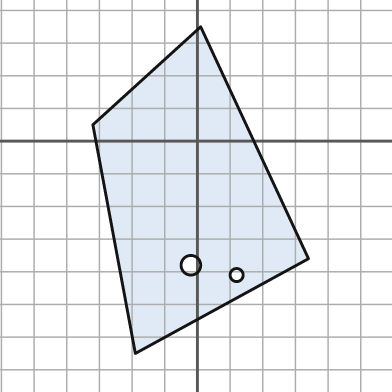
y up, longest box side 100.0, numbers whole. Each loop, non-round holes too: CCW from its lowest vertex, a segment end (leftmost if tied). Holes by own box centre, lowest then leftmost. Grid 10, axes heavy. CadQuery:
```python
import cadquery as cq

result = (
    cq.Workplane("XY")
    .moveTo(-19.0, -65.0)
    .lineTo(34.0, -36.0)
    .lineTo(1.0, 35.0)
    .lineTo(-32.0, 5.0)
    .close()
    .moveTo(12.0, -41.0)
    .circle(2.0)
    .moveTo(-2.0, -38.0)
    .circle(3.0)
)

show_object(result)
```